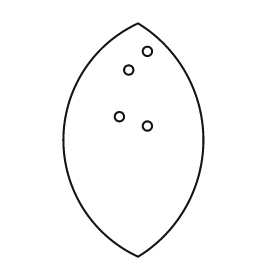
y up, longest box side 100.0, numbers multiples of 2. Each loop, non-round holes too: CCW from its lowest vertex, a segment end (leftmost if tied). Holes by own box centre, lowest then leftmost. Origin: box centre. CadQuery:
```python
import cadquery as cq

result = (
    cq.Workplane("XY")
    .moveTo(2.0, -50.0)
    .threePointArc((30.0, 0.0), (2.0, 50.0))
    .threePointArc((-30.0, 0.0), (2.0, -50.0))
    .close()
    .moveTo(6.0, 6.0)
    .circle(2.0)
    .moveTo(-6.0, 10.0)
    .circle(2.0)
    .moveTo(-2.0, 30.0)
    .circle(2.0)
    .moveTo(6.0, 38.0)
    .circle(2.0)
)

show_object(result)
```